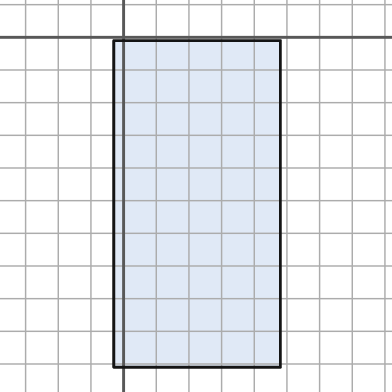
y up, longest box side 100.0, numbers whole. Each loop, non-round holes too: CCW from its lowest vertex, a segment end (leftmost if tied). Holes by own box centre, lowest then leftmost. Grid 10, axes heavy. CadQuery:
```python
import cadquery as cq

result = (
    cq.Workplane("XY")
    .moveTo(-3.0, -101.0)
    .lineTo(48.0, -101.0)
    .lineTo(48.0, -1.0)
    .lineTo(-3.0, -1.0)
    .close()
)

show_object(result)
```